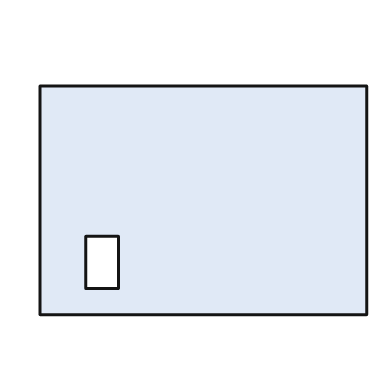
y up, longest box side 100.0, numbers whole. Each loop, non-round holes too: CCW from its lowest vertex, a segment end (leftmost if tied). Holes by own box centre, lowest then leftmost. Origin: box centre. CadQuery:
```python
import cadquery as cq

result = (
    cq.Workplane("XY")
    .moveTo(-50.0, -35.0)
    .lineTo(50.0, -35.0)
    .lineTo(50.0, 35.0)
    .lineTo(-50.0, 35.0)
    .close()
    .moveTo(-36.0, -27.0)
    .lineTo(-26.0, -27.0)
    .lineTo(-26.0, -11.0)
    .lineTo(-36.0, -11.0)
    .close()
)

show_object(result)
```